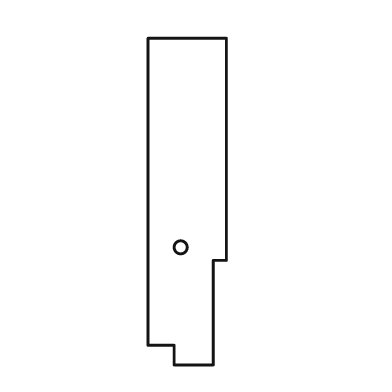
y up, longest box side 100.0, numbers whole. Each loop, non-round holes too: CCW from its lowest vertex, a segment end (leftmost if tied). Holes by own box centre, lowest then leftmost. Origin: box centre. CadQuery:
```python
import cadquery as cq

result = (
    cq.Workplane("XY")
    .moveTo(-4.0, -50.0)
    .lineTo(8.0, -50.0)
    .lineTo(8.0, -18.0)
    .lineTo(12.0, -18.0)
    .lineTo(12.0, 50.0)
    .lineTo(-12.0, 50.0)
    .lineTo(-12.0, -44.0)
    .lineTo(-4.0, -44.0)
    .close()
    .moveTo(-2.0, -14.0)
    .circle(2.0)
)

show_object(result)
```